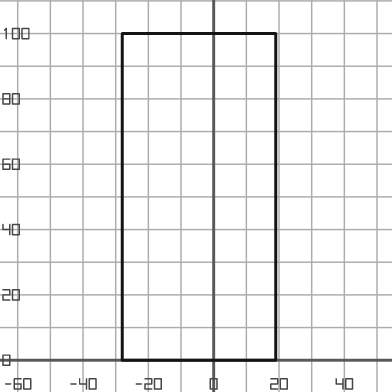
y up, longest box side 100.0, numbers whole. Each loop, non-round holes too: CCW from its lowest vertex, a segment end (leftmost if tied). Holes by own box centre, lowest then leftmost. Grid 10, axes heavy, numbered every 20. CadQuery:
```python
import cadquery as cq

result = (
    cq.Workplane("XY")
    .moveTo(-28.0, 0.0)
    .lineTo(19.0, 0.0)
    .lineTo(19.0, 100.0)
    .lineTo(-28.0, 100.0)
    .close()
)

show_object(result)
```